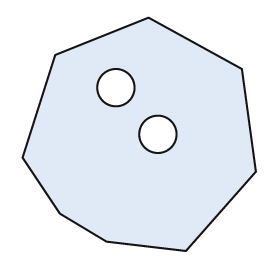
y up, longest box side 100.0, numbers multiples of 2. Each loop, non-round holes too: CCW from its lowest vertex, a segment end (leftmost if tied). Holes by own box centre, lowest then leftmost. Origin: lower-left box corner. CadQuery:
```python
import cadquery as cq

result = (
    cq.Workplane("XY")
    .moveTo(70.0, 0.0)
    .lineTo(100.0, 34.0)
    .lineTo(94.0, 78.0)
    .lineTo(54.0, 100.0)
    .lineTo(14.0, 84.0)
    .lineTo(0.0, 40.0)
    .lineTo(16.0, 16.0)
    .lineTo(36.0, 4.0)
    .close()
    .moveTo(58.0, 50.0)
    .circle(8.0)
    .moveTo(40.0, 70.0)
    .circle(8.0)
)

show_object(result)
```